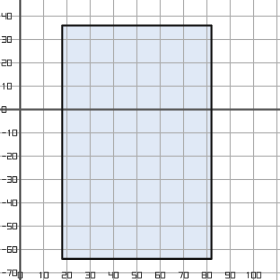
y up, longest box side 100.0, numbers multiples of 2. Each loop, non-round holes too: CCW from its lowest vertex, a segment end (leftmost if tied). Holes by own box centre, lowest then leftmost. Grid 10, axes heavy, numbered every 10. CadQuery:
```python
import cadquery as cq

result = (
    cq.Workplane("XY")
    .moveTo(18.0, -64.0)
    .lineTo(82.0, -64.0)
    .lineTo(82.0, 36.0)
    .lineTo(18.0, 36.0)
    .close()
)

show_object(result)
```